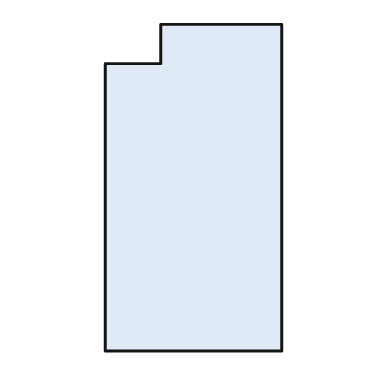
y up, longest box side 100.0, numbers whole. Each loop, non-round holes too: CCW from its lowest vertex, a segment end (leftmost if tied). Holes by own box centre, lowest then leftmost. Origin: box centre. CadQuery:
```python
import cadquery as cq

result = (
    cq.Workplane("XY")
    .moveTo(-27.0, -50.0)
    .lineTo(27.0, -50.0)
    .lineTo(27.0, 50.0)
    .lineTo(-10.0, 50.0)
    .lineTo(-10.0, 38.0)
    .lineTo(-27.0, 38.0)
    .close()
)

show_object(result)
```